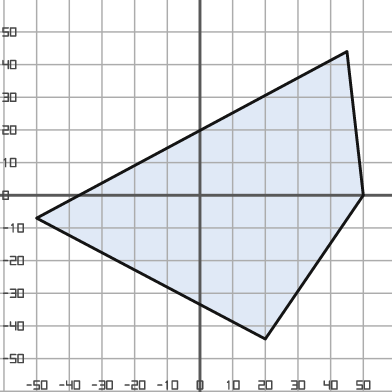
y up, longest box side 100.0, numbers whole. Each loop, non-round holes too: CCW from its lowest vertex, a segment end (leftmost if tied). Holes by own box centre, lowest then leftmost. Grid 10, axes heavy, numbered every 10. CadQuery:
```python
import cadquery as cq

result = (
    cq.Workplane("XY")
    .moveTo(20.0, -44.0)
    .lineTo(50.0, 0.0)
    .lineTo(45.0, 44.0)
    .lineTo(-50.0, -7.0)
    .close()
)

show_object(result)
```